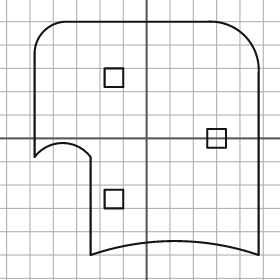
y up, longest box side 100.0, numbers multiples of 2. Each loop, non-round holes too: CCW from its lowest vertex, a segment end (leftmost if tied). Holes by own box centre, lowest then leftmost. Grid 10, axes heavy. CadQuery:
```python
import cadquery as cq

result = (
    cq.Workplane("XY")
    .moveTo(-24.0, -50.0)
    .threePointArc((12.0, -44.0), (48.0, -50.0))
    .lineTo(48.0, 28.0)
    .threePointArc((42.0, 44.0), (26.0, 50.0))
    .lineTo(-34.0, 50.0)
    .threePointArc((-44.0, 46.0), (-48.0, 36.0))
    .lineTo(-48.0, -8.0)
    .threePointArc((-36.0, -2.0), (-24.0, -8.0))
    .close()
    .moveTo(-18.0, -30.0)
    .lineTo(-10.0, -30.0)
    .lineTo(-10.0, -22.0)
    .lineTo(-18.0, -22.0)
    .close()
    .moveTo(26.0, -4.0)
    .lineTo(34.0, -4.0)
    .lineTo(34.0, 4.0)
    .lineTo(26.0, 4.0)
    .close()
    .moveTo(-18.0, 22.0)
    .lineTo(-10.0, 22.0)
    .lineTo(-10.0, 30.0)
    .lineTo(-18.0, 30.0)
    .close()
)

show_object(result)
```